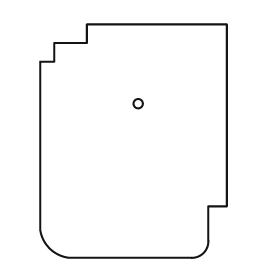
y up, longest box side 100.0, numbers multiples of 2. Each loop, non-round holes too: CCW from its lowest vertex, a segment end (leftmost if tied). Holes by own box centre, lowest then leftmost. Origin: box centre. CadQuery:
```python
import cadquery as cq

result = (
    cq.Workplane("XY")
    .moveTo(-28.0, -50.0)
    .lineTo(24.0, -50.0)
    .threePointArc((30.0, -48.0), (32.0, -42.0))
    .lineTo(32.0, -28.0)
    .lineTo(40.0, -28.0)
    .lineTo(40.0, 50.0)
    .lineTo(-20.0, 50.0)
    .lineTo(-20.0, 42.0)
    .lineTo(-34.0, 42.0)
    .lineTo(-34.0, 34.0)
    .lineTo(-40.0, 34.0)
    .lineTo(-40.0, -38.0)
    .threePointArc((-36.0, -46.0), (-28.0, -50.0))
    .close()
    .moveTo(2.0, 16.0)
    .circle(2.0)
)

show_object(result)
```